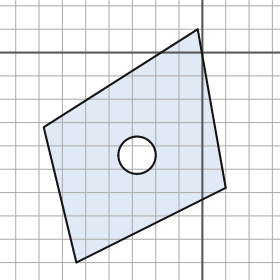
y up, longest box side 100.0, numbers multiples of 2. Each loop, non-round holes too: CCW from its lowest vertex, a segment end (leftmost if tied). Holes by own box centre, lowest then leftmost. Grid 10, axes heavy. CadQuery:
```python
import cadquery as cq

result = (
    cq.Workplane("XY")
    .moveTo(-54.0, -90.0)
    .lineTo(10.0, -58.0)
    .lineTo(-2.0, 10.0)
    .lineTo(-68.0, -32.0)
    .close()
    .moveTo(-28.0, -44.0)
    .circle(8.0)
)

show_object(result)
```